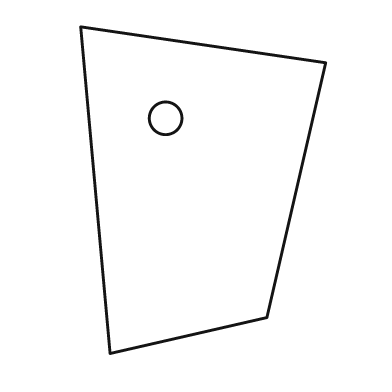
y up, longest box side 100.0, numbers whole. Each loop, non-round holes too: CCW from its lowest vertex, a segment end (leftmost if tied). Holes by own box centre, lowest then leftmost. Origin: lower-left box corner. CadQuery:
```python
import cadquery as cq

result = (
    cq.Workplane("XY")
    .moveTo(9.0, 0.0)
    .lineTo(57.0, 11.0)
    .lineTo(75.0, 89.0)
    .lineTo(0.0, 100.0)
    .close()
    .moveTo(26.0, 72.0)
    .circle(5.0)
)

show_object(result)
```